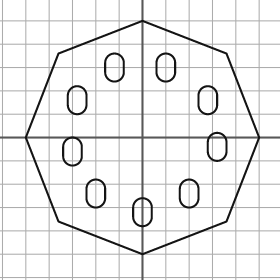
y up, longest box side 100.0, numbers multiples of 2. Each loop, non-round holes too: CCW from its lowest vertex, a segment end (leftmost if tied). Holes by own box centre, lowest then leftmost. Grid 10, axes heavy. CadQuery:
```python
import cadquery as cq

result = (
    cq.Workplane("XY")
    .moveTo(0.0, -50.0)
    .lineTo(36.0, -36.0)
    .lineTo(50.0, 0.0)
    .lineTo(36.0, 36.0)
    .lineTo(0.0, 50.0)
    .lineTo(-36.0, 36.0)
    .lineTo(-50.0, 0.0)
    .lineTo(-36.0, -36.0)
    .close()
    .moveTo(-4.0, -34.0)
    .threePointArc((0.0, -38.0), (4.0, -34.0))
    .lineTo(4.0, -30.0)
    .threePointArc((0.0, -26.0), (-4.0, -30.0))
    .close()
    .moveTo(-24.0, -26.0)
    .threePointArc((-20.0, -30.0), (-16.0, -26.0))
    .lineTo(-16.0, -22.0)
    .threePointArc((-20.0, -18.0), (-24.0, -22.0))
    .close()
    .moveTo(16.0, -26.0)
    .threePointArc((20.0, -30.0), (24.0, -26.0))
    .lineTo(24.0, -22.0)
    .threePointArc((20.0, -18.0), (16.0, -22.0))
    .close()
    .moveTo(-34.0, -8.0)
    .threePointArc((-30.0, -12.0), (-26.0, -8.0))
    .lineTo(-26.0, -4.0)
    .threePointArc((-30.0, 0.0), (-34.0, -4.0))
    .close()
    .moveTo(28.0, -6.0)
    .threePointArc((32.0, -10.0), (36.0, -6.0))
    .lineTo(36.0, -2.0)
    .threePointArc((32.0, 2.0), (28.0, -2.0))
    .close()
    .moveTo(-32.0, 14.0)
    .threePointArc((-28.0, 10.0), (-24.0, 14.0))
    .lineTo(-24.0, 18.0)
    .threePointArc((-28.0, 22.0), (-32.0, 18.0))
    .close()
    .moveTo(24.0, 14.0)
    .threePointArc((28.0, 10.0), (32.0, 14.0))
    .lineTo(32.0, 18.0)
    .threePointArc((28.0, 22.0), (24.0, 18.0))
    .close()
    .moveTo(-16.0, 28.0)
    .threePointArc((-12.0, 24.0), (-8.0, 28.0))
    .lineTo(-8.0, 32.0)
    .threePointArc((-12.0, 36.0), (-16.0, 32.0))
    .close()
    .moveTo(6.0, 28.0)
    .threePointArc((10.0, 24.0), (14.0, 28.0))
    .lineTo(14.0, 32.0)
    .threePointArc((10.0, 36.0), (6.0, 32.0))
    .close()
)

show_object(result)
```